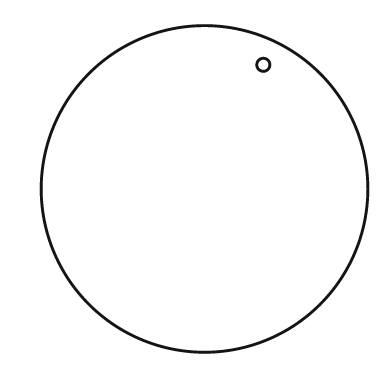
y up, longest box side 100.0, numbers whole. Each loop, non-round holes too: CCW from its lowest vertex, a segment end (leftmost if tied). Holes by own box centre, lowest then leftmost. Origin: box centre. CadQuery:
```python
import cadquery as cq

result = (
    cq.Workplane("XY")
    .moveTo(0.0, 0.0)
    .circle(50.0)
    .moveTo(18.0, 38.0)
    .circle(2.0)
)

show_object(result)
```